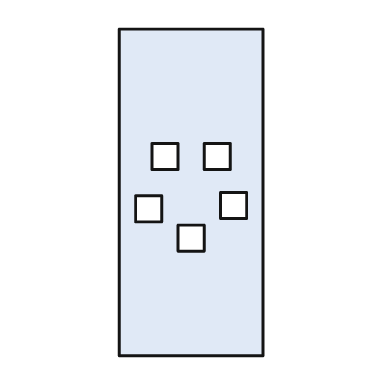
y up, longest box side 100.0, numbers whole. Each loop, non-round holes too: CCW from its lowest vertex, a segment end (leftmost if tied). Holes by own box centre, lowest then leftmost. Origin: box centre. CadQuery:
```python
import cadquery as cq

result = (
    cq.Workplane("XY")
    .moveTo(-22.0, -50.0)
    .lineTo(22.0, -50.0)
    .lineTo(22.0, 50.0)
    .lineTo(-22.0, 50.0)
    .close()
    .moveTo(-4.0, -18.0)
    .lineTo(4.0, -18.0)
    .lineTo(4.0, -10.0)
    .lineTo(-4.0, -10.0)
    .close()
    .moveTo(-17.0, -9.0)
    .lineTo(-9.0, -9.0)
    .lineTo(-9.0, -1.0)
    .lineTo(-17.0, -1.0)
    .close()
    .moveTo(9.0, -8.0)
    .lineTo(17.0, -8.0)
    .lineTo(17.0, 0.0)
    .lineTo(9.0, 0.0)
    .close()
    .moveTo(-12.0, 7.0)
    .lineTo(-4.0, 7.0)
    .lineTo(-4.0, 15.0)
    .lineTo(-12.0, 15.0)
    .close()
    .moveTo(4.0, 7.0)
    .lineTo(12.0, 7.0)
    .lineTo(12.0, 15.0)
    .lineTo(4.0, 15.0)
    .close()
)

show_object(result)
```